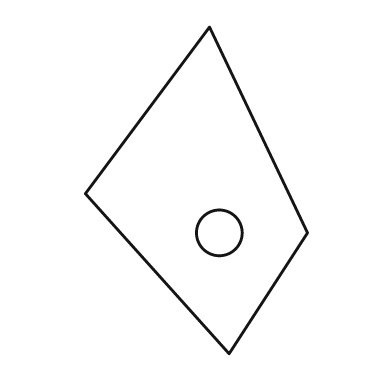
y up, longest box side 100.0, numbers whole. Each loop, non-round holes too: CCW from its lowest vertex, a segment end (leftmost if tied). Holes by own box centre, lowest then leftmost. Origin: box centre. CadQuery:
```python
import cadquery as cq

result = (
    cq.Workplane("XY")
    .moveTo(10.0, -50.0)
    .lineTo(34.0, -13.0)
    .lineTo(4.0, 50.0)
    .lineTo(-34.0, -1.0)
    .close()
    .moveTo(7.0, -13.0)
    .circle(7.0)
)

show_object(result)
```